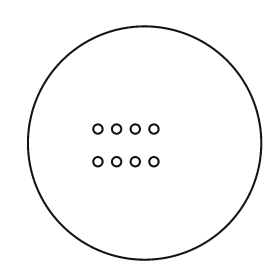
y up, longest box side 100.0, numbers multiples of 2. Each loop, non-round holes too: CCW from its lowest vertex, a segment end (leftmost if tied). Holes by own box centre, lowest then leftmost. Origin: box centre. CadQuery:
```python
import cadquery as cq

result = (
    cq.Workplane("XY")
    .moveTo(0.0, 0.0)
    .circle(50.0)
    .moveTo(-20.0, -8.0)
    .circle(2.0)
    .moveTo(-12.0, -8.0)
    .circle(2.0)
    .moveTo(-4.0, -8.0)
    .circle(2.0)
    .moveTo(4.0, -8.0)
    .circle(2.0)
    .moveTo(-20.0, 6.0)
    .circle(2.0)
    .moveTo(-12.0, 6.0)
    .circle(2.0)
    .moveTo(-4.0, 6.0)
    .circle(2.0)
    .moveTo(4.0, 6.0)
    .circle(2.0)
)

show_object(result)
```